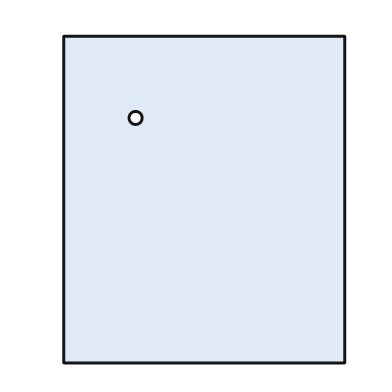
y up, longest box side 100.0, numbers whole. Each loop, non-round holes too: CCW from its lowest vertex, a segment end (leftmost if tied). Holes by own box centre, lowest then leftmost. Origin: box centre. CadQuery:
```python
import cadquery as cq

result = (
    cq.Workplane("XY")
    .moveTo(-43.0, -50.0)
    .lineTo(43.0, -50.0)
    .lineTo(43.0, 50.0)
    .lineTo(-43.0, 50.0)
    .close()
    .moveTo(-21.0, 25.0)
    .circle(2.0)
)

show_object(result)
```